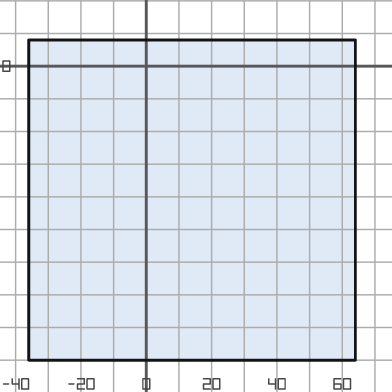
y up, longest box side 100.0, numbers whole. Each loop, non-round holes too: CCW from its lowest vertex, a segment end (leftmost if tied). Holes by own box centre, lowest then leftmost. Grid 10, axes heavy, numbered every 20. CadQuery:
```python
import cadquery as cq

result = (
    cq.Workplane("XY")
    .moveTo(-36.0, -90.0)
    .lineTo(64.0, -90.0)
    .lineTo(64.0, 8.0)
    .lineTo(-36.0, 8.0)
    .close()
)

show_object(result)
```